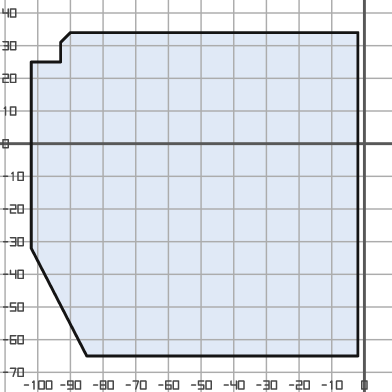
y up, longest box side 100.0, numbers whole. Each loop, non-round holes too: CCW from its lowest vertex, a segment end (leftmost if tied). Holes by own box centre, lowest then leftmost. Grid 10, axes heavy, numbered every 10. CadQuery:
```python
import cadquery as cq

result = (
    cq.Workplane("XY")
    .moveTo(-85.0, -65.0)
    .lineTo(-2.0, -65.0)
    .lineTo(-2.0, 34.0)
    .lineTo(-90.0, 34.0)
    .lineTo(-93.0, 31.0)
    .lineTo(-93.0, 25.0)
    .lineTo(-102.0, 25.0)
    .lineTo(-102.0, -32.0)
    .close()
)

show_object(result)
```